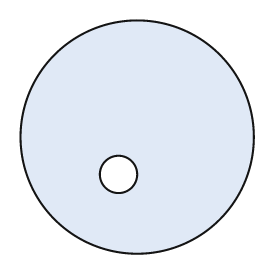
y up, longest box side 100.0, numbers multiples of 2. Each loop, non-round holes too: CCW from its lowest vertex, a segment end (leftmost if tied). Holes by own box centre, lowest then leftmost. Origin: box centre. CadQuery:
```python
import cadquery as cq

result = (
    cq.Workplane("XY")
    .moveTo(0.0, 0.0)
    .circle(50.0)
    .moveTo(-8.0, -16.0)
    .circle(8.0)
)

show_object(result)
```